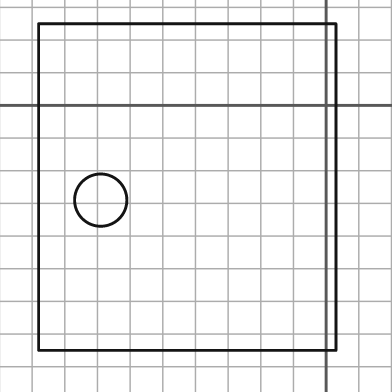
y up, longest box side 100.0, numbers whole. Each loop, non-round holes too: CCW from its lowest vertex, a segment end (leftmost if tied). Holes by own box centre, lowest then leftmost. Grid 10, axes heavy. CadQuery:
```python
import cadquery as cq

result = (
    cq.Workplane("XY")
    .moveTo(-88.0, -75.0)
    .lineTo(3.0, -75.0)
    .lineTo(3.0, 25.0)
    .lineTo(-88.0, 25.0)
    .close()
    .moveTo(-69.0, -29.0)
    .circle(8.0)
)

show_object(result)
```